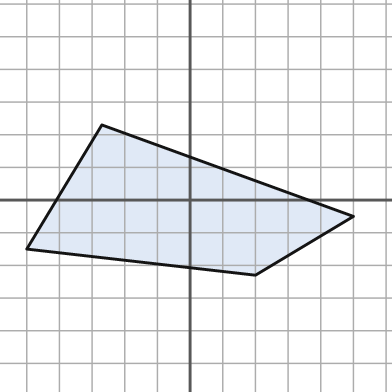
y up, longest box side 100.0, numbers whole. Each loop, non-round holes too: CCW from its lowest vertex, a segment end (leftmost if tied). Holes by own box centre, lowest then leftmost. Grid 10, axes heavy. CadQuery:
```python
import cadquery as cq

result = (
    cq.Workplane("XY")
    .moveTo(20.0, -23.0)
    .lineTo(50.0, -5.0)
    .lineTo(-27.0, 23.0)
    .lineTo(-50.0, -15.0)
    .close()
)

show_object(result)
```